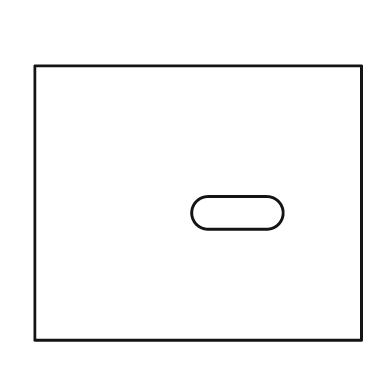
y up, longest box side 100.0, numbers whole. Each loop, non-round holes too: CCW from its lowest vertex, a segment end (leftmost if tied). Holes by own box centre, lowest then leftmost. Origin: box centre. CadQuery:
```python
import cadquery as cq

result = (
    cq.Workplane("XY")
    .moveTo(-50.0, -42.0)
    .lineTo(50.0, -42.0)
    .lineTo(50.0, 42.0)
    .lineTo(-50.0, 42.0)
    .close()
    .moveTo(3.0, -8.0)
    .lineTo(21.0, -8.0)
    .threePointArc((26.0, -3.0), (21.0, 2.0))
    .lineTo(3.0, 2.0)
    .threePointArc((-2.0, -3.0), (3.0, -8.0))
    .close()
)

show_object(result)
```